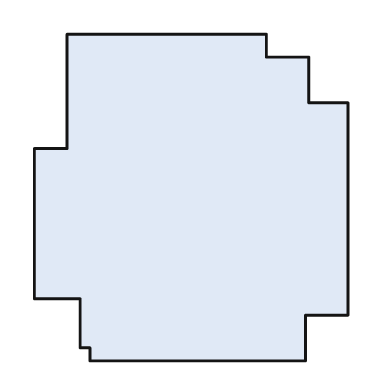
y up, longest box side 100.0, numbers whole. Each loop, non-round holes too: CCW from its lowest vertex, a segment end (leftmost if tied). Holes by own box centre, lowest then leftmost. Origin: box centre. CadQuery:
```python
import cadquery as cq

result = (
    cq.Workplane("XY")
    .moveTo(-31.0, -50.0)
    .lineTo(35.0, -50.0)
    .lineTo(35.0, -36.0)
    .lineTo(48.0, -36.0)
    .lineTo(48.0, 29.0)
    .lineTo(36.0, 29.0)
    .lineTo(36.0, 43.0)
    .lineTo(23.0, 43.0)
    .lineTo(23.0, 50.0)
    .lineTo(-38.0, 50.0)
    .lineTo(-38.0, 15.0)
    .lineTo(-48.0, 15.0)
    .lineTo(-48.0, -31.0)
    .lineTo(-34.0, -31.0)
    .lineTo(-34.0, -46.0)
    .lineTo(-31.0, -46.0)
    .close()
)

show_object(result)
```